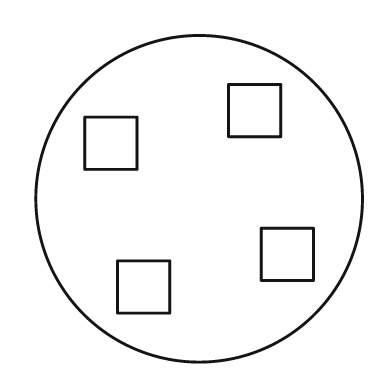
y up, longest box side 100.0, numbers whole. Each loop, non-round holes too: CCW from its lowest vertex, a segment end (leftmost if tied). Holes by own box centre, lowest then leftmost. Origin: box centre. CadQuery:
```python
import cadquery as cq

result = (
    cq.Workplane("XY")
    .moveTo(0.0, 0.0)
    .circle(50.0)
    .moveTo(-25.0, -35.0)
    .lineTo(-9.0, -35.0)
    .lineTo(-9.0, -19.0)
    .lineTo(-25.0, -19.0)
    .close()
    .moveTo(19.0, -25.0)
    .lineTo(35.0, -25.0)
    .lineTo(35.0, -9.0)
    .lineTo(19.0, -9.0)
    .close()
    .moveTo(-35.0, 9.0)
    .lineTo(-19.0, 9.0)
    .lineTo(-19.0, 25.0)
    .lineTo(-35.0, 25.0)
    .close()
    .moveTo(9.0, 19.0)
    .lineTo(25.0, 19.0)
    .lineTo(25.0, 35.0)
    .lineTo(9.0, 35.0)
    .close()
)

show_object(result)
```